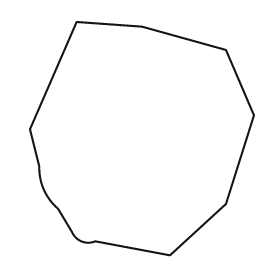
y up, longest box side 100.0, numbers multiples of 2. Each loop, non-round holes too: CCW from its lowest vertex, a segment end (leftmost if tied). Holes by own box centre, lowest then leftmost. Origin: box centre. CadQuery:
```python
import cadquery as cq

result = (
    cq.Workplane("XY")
    .moveTo(12.0, -50.0)
    .lineTo(36.0, -28.0)
    .lineTo(48.0, 10.0)
    .lineTo(36.0, 38.0)
    .lineTo(0.0, 48.0)
    .lineTo(-28.0, 50.0)
    .lineTo(-48.0, 4.0)
    .lineTo(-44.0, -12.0)
    .threePointArc((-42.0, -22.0), (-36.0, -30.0))
    .lineTo(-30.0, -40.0)
    .threePointArc((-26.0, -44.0), (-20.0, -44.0))
    .close()
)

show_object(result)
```